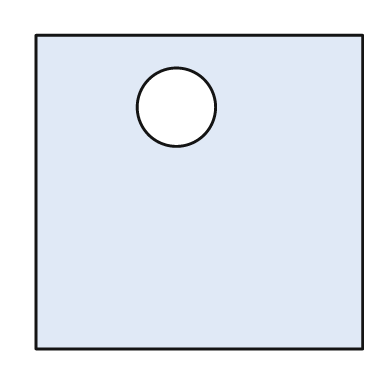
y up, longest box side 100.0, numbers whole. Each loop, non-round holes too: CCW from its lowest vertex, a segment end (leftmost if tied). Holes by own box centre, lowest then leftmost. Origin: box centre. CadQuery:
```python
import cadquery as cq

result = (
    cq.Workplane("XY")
    .moveTo(-50.0, -48.0)
    .lineTo(50.0, -48.0)
    .lineTo(50.0, 48.0)
    .lineTo(-50.0, 48.0)
    .close()
    .moveTo(-7.0, 26.0)
    .circle(12.0)
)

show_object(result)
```